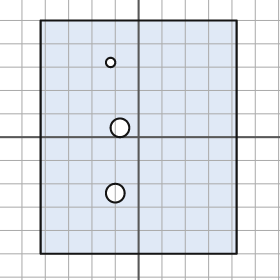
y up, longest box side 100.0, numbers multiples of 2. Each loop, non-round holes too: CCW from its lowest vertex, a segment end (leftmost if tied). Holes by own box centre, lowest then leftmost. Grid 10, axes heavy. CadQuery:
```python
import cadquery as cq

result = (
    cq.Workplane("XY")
    .moveTo(-42.0, -50.0)
    .lineTo(42.0, -50.0)
    .lineTo(42.0, 50.0)
    .lineTo(-42.0, 50.0)
    .close()
    .moveTo(-10.0, -24.0)
    .circle(4.0)
    .moveTo(-8.0, 4.0)
    .circle(4.0)
    .moveTo(-12.0, 32.0)
    .circle(2.0)
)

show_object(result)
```